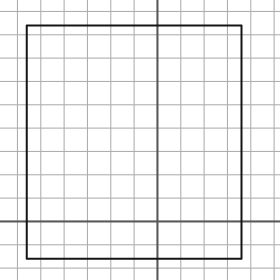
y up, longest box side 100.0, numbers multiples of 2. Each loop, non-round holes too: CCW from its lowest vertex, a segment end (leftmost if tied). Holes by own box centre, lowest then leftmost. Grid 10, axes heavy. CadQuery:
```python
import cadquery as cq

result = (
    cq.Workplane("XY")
    .moveTo(-56.0, -16.0)
    .lineTo(36.0, -16.0)
    .lineTo(36.0, 84.0)
    .lineTo(-56.0, 84.0)
    .close()
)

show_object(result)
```